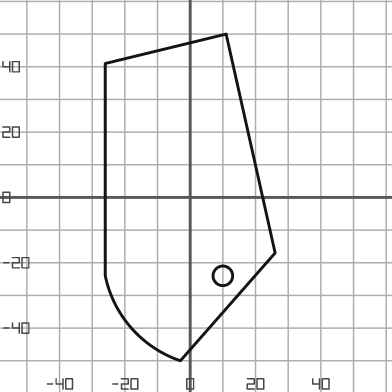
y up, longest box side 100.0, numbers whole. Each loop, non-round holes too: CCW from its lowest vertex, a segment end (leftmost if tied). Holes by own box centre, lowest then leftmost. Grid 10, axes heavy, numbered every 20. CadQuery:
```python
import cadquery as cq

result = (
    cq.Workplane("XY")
    .moveTo(-3.0, -50.0)
    .lineTo(26.0, -17.0)
    .lineTo(11.0, 50.0)
    .lineTo(-26.0, 41.0)
    .lineTo(-26.0, -24.0)
    .threePointArc((-18.0, -40.0), (-3.0, -50.0))
    .close()
    .moveTo(10.0, -24.0)
    .circle(3.0)
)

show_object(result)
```